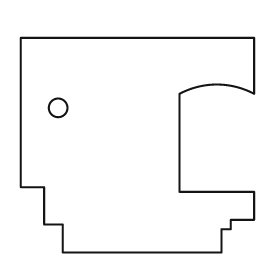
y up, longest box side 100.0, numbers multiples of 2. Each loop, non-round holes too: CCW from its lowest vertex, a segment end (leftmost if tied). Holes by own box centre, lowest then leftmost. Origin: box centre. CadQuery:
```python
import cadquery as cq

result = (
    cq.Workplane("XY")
    .moveTo(-32.0, -46.0)
    .lineTo(36.0, -46.0)
    .lineTo(36.0, -36.0)
    .lineTo(40.0, -36.0)
    .lineTo(40.0, -32.0)
    .lineTo(50.0, -32.0)
    .lineTo(50.0, -20.0)
    .lineTo(18.0, -20.0)
    .lineTo(18.0, 22.0)
    .threePointArc((34.0, 26.0), (50.0, 22.0))
    .lineTo(50.0, 46.0)
    .lineTo(-50.0, 46.0)
    .lineTo(-50.0, -18.0)
    .lineTo(-40.0, -18.0)
    .lineTo(-40.0, -34.0)
    .lineTo(-32.0, -34.0)
    .close()
    .moveTo(-34.0, 16.0)
    .circle(4.0)
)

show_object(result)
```